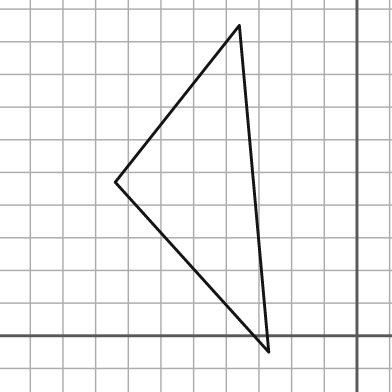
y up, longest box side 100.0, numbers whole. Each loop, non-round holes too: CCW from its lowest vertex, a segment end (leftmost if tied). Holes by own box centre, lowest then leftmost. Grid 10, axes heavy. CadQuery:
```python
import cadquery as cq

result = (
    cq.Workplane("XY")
    .moveTo(-27.0, -5.0)
    .lineTo(-36.0, 95.0)
    .lineTo(-74.0, 47.0)
    .close()
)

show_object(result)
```